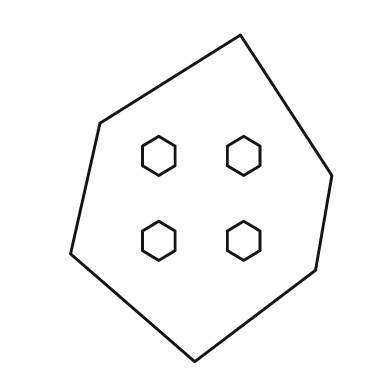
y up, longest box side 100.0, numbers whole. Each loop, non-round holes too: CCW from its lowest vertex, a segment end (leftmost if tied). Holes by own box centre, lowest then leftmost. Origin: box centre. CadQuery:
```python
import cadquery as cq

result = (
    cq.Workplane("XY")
    .moveTo(-2.0, -50.0)
    .lineTo(35.0, -22.0)
    .lineTo(40.0, 7.0)
    .lineTo(12.0, 50.0)
    .lineTo(-31.0, 23.0)
    .lineTo(-40.0, -17.0)
    .close()
    .moveTo(-13.0, -19.0)
    .lineTo(-8.0, -16.0)
    .lineTo(-8.0, -10.0)
    .lineTo(-13.0, -7.0)
    .lineTo(-18.0, -10.0)
    .lineTo(-18.0, -16.0)
    .close()
    .moveTo(13.0, -19.0)
    .lineTo(18.0, -16.0)
    .lineTo(18.0, -10.0)
    .lineTo(13.0, -7.0)
    .lineTo(8.0, -10.0)
    .lineTo(8.0, -16.0)
    .close()
    .moveTo(-13.0, 7.0)
    .lineTo(-8.0, 10.0)
    .lineTo(-8.0, 16.0)
    .lineTo(-13.0, 19.0)
    .lineTo(-18.0, 16.0)
    .lineTo(-18.0, 10.0)
    .close()
    .moveTo(13.0, 7.0)
    .lineTo(18.0, 10.0)
    .lineTo(18.0, 16.0)
    .lineTo(13.0, 19.0)
    .lineTo(8.0, 16.0)
    .lineTo(8.0, 10.0)
    .close()
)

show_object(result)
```